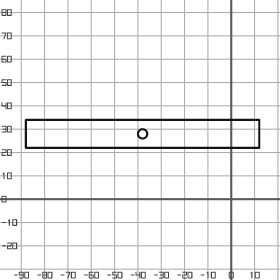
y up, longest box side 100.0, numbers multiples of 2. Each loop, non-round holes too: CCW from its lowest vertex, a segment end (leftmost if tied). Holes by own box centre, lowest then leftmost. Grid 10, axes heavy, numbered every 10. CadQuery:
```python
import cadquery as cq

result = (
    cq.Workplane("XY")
    .moveTo(-88.0, 22.0)
    .lineTo(12.0, 22.0)
    .lineTo(12.0, 34.0)
    .lineTo(-88.0, 34.0)
    .close()
    .moveTo(-38.0, 28.0)
    .circle(2.0)
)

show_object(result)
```